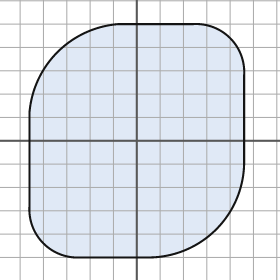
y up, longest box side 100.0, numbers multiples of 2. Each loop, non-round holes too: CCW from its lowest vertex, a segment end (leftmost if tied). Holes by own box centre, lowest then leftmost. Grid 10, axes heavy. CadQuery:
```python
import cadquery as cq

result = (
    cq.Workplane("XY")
    .moveTo(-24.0, -50.0)
    .lineTo(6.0, -50.0)
    .threePointArc((34.0, -38.0), (46.0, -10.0))
    .lineTo(46.0, 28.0)
    .threePointArc((40.0, 44.0), (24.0, 50.0))
    .lineTo(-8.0, 50.0)
    .threePointArc((-34.0, 38.0), (-46.0, 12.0))
    .lineTo(-46.0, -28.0)
    .threePointArc((-40.0, -44.0), (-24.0, -50.0))
    .close()
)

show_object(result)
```